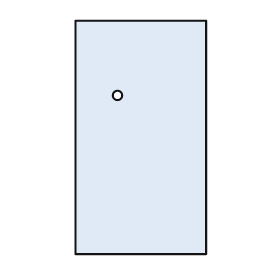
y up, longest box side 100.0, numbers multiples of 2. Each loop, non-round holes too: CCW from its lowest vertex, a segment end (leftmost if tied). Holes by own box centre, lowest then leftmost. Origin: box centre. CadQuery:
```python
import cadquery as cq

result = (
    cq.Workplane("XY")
    .moveTo(-28.0, -50.0)
    .lineTo(28.0, -50.0)
    .lineTo(28.0, 50.0)
    .lineTo(-28.0, 50.0)
    .close()
    .moveTo(-10.0, 18.0)
    .circle(2.0)
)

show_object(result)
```